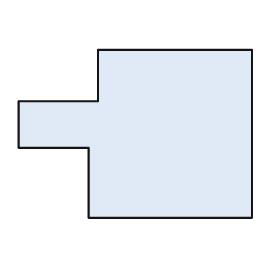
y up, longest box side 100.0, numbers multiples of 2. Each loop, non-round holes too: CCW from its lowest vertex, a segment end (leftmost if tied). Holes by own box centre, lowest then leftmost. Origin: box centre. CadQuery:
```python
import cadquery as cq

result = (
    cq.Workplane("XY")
    .moveTo(-20.0, -36.0)
    .lineTo(50.0, -36.0)
    .lineTo(50.0, 36.0)
    .lineTo(-16.0, 36.0)
    .lineTo(-16.0, 14.0)
    .lineTo(-50.0, 14.0)
    .lineTo(-50.0, -6.0)
    .lineTo(-20.0, -6.0)
    .close()
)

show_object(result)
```